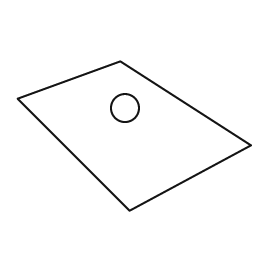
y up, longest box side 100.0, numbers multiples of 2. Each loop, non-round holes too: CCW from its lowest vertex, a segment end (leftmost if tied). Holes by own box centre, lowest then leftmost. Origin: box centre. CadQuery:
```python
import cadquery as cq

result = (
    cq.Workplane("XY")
    .moveTo(-2.0, -32.0)
    .lineTo(50.0, -4.0)
    .lineTo(-6.0, 32.0)
    .lineTo(-50.0, 16.0)
    .close()
    .moveTo(-4.0, 12.0)
    .circle(6.0)
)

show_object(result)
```